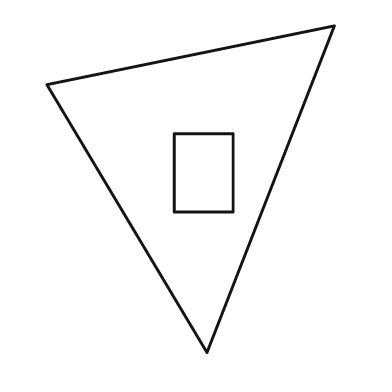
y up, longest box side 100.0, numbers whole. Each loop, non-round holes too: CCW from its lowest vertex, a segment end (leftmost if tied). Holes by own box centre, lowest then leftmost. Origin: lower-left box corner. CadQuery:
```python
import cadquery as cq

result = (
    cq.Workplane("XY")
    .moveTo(49.0, 0.0)
    .lineTo(88.0, 100.0)
    .lineTo(0.0, 82.0)
    .close()
    .moveTo(39.0, 43.0)
    .lineTo(57.0, 43.0)
    .lineTo(57.0, 67.0)
    .lineTo(39.0, 67.0)
    .close()
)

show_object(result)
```